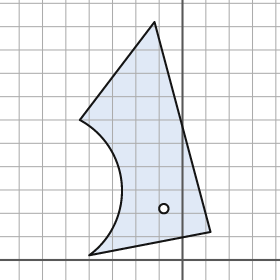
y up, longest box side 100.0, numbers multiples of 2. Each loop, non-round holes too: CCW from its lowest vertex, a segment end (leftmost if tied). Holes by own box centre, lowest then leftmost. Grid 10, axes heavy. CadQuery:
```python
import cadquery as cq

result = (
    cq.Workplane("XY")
    .moveTo(-40.0, 2.0)
    .lineTo(12.0, 12.0)
    .lineTo(-12.0, 102.0)
    .lineTo(-44.0, 60.0)
    .threePointArc((-26.0, 32.0), (-40.0, 2.0))
    .close()
    .moveTo(-8.0, 22.0)
    .circle(2.0)
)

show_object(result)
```